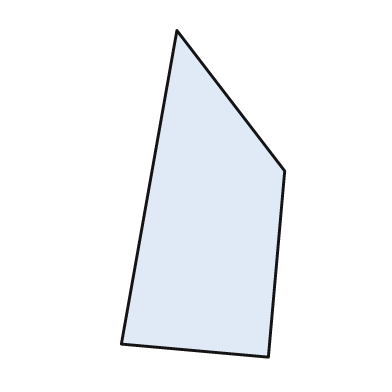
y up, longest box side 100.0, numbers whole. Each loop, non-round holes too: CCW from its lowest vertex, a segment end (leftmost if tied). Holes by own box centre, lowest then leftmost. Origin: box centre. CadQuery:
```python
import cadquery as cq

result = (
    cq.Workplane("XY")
    .moveTo(20.0, -50.0)
    .lineTo(25.0, 7.0)
    .lineTo(-8.0, 50.0)
    .lineTo(-25.0, -46.0)
    .close()
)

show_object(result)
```